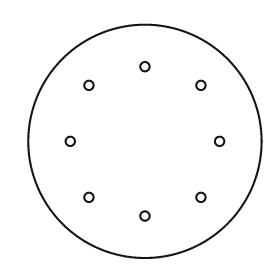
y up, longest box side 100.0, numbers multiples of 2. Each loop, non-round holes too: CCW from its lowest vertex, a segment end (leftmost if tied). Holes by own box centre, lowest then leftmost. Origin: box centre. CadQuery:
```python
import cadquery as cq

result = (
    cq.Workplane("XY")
    .moveTo(0.0, 0.0)
    .circle(50.0)
    .moveTo(0.0, -32.0)
    .circle(2.0)
    .moveTo(-24.0, -24.0)
    .circle(2.0)
    .moveTo(24.0, -24.0)
    .circle(2.0)
    .moveTo(-32.0, 0.0)
    .circle(2.0)
    .moveTo(32.0, 0.0)
    .circle(2.0)
    .moveTo(-24.0, 24.0)
    .circle(2.0)
    .moveTo(24.0, 24.0)
    .circle(2.0)
    .moveTo(0.0, 32.0)
    .circle(2.0)
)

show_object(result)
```